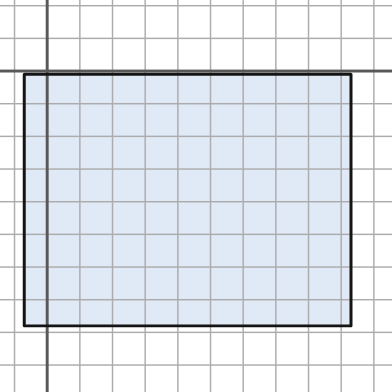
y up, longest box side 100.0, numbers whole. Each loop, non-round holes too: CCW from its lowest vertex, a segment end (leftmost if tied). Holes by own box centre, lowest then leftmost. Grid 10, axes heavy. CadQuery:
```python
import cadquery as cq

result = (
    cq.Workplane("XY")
    .moveTo(-7.0, -78.0)
    .lineTo(93.0, -78.0)
    .lineTo(93.0, -1.0)
    .lineTo(-7.0, -1.0)
    .close()
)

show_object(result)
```